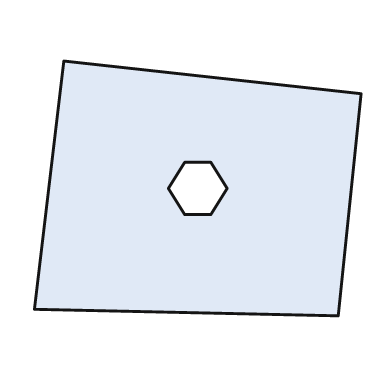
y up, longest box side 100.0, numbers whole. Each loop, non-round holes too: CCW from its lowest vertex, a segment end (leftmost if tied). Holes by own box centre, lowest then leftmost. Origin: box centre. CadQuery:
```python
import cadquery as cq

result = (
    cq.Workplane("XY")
    .moveTo(43.0, -39.0)
    .lineTo(50.0, 29.0)
    .lineTo(-41.0, 39.0)
    .lineTo(-50.0, -37.0)
    .close()
    .moveTo(-4.0, -8.0)
    .lineTo(4.0, -8.0)
    .lineTo(9.0, 0.0)
    .lineTo(4.0, 8.0)
    .lineTo(-4.0, 8.0)
    .lineTo(-9.0, 0.0)
    .close()
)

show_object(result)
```